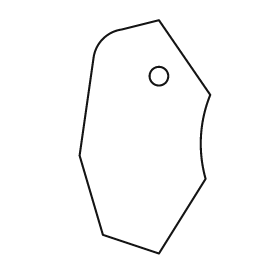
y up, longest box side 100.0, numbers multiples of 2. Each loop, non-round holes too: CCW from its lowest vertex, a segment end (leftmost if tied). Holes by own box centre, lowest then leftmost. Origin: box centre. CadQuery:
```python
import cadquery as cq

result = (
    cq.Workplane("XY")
    .moveTo(6.0, -50.0)
    .lineTo(26.0, -18.0)
    .threePointArc((24.0, 0.0), (28.0, 18.0))
    .lineTo(6.0, 50.0)
    .lineTo(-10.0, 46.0)
    .threePointArc((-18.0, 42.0), (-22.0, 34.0))
    .lineTo(-28.0, -8.0)
    .lineTo(-18.0, -42.0)
    .close()
    .moveTo(6.0, 26.0)
    .circle(4.0)
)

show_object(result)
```